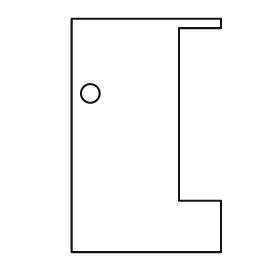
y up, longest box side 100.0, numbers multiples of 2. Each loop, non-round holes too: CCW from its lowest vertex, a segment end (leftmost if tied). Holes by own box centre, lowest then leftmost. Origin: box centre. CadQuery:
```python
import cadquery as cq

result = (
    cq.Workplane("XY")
    .moveTo(-32.0, -50.0)
    .lineTo(32.0, -50.0)
    .lineTo(32.0, -28.0)
    .lineTo(14.0, -28.0)
    .lineTo(14.0, 46.0)
    .lineTo(32.0, 46.0)
    .lineTo(32.0, 50.0)
    .lineTo(-32.0, 50.0)
    .close()
    .moveTo(-24.0, 18.0)
    .circle(4.0)
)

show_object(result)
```